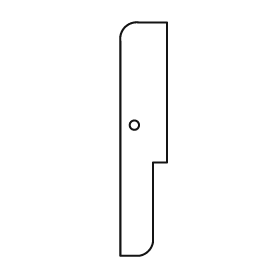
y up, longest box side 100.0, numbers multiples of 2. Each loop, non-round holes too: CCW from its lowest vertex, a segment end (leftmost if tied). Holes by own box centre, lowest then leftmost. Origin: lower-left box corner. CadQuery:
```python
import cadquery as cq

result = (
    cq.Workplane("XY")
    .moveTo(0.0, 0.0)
    .lineTo(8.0, 0.0)
    .threePointArc((12.0, 2.0), (14.0, 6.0))
    .lineTo(14.0, 40.0)
    .lineTo(20.0, 40.0)
    .lineTo(20.0, 100.0)
    .lineTo(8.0, 100.0)
    .threePointArc((2.0, 98.0), (0.0, 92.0))
    .close()
    .moveTo(6.0, 56.0)
    .circle(2.0)
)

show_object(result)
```